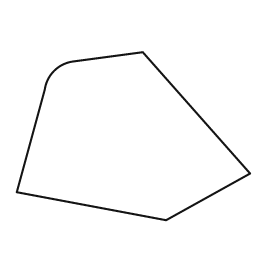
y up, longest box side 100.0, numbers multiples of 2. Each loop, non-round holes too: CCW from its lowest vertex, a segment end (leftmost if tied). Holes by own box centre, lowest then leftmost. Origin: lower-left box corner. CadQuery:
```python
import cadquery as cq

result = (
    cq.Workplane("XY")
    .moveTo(64.0, 0.0)
    .lineTo(100.0, 20.0)
    .lineTo(54.0, 72.0)
    .lineTo(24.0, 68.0)
    .threePointArc((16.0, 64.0), (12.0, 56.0))
    .lineTo(0.0, 12.0)
    .close()
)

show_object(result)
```